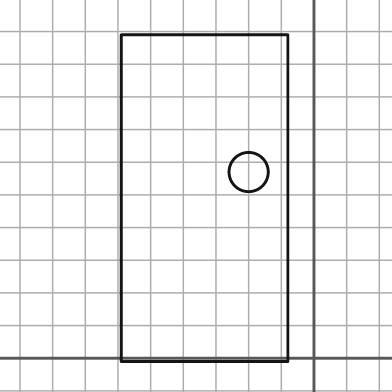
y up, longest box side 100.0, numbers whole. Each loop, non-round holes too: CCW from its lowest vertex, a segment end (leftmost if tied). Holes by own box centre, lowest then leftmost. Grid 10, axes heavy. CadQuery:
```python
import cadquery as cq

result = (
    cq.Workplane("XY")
    .moveTo(-59.0, -1.0)
    .lineTo(-8.0, -1.0)
    .lineTo(-8.0, 99.0)
    .lineTo(-59.0, 99.0)
    .close()
    .moveTo(-20.0, 57.0)
    .circle(6.0)
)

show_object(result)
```